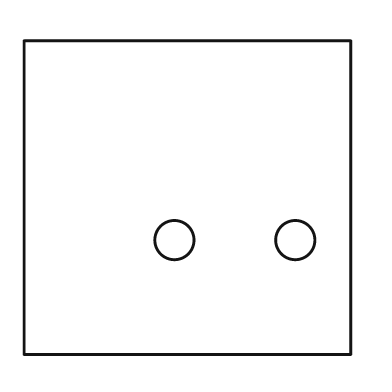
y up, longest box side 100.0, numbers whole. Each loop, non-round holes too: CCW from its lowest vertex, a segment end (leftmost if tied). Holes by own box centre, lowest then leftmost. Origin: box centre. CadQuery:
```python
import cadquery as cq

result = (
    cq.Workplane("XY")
    .moveTo(-50.0, -48.0)
    .lineTo(50.0, -48.0)
    .lineTo(50.0, 48.0)
    .lineTo(-50.0, 48.0)
    .close()
    .moveTo(-4.0, -13.0)
    .circle(6.0)
    .moveTo(33.0, -13.0)
    .circle(6.0)
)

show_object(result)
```